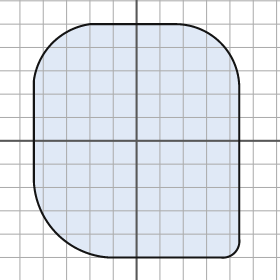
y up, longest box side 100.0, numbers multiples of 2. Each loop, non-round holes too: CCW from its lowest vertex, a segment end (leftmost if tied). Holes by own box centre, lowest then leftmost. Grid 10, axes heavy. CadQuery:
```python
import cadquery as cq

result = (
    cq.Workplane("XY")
    .moveTo(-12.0, -50.0)
    .lineTo(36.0, -50.0)
    .threePointArc((42.0, -48.0), (44.0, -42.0))
    .lineTo(44.0, 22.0)
    .threePointArc((36.0, 42.0), (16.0, 50.0))
    .lineTo(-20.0, 50.0)
    .threePointArc((-36.0, 42.0), (-44.0, 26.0))
    .lineTo(-44.0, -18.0)
    .threePointArc((-34.0, -40.0), (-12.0, -50.0))
    .close()
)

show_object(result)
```